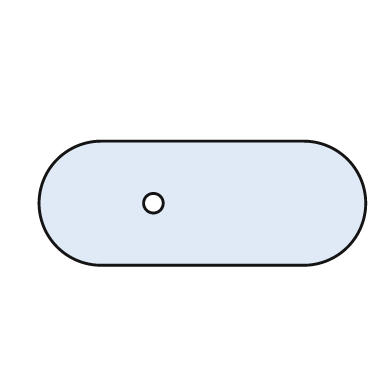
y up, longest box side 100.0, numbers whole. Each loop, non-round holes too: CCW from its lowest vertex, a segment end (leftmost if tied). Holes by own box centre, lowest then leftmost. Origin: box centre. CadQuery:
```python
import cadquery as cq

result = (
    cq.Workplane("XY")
    .moveTo(-31.0, -19.0)
    .lineTo(31.0, -19.0)
    .threePointArc((50.0, 0.0), (31.0, 19.0))
    .lineTo(-31.0, 19.0)
    .threePointArc((-50.0, 0.0), (-31.0, -19.0))
    .close()
    .moveTo(-15.0, 0.0)
    .circle(3.0)
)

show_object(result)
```